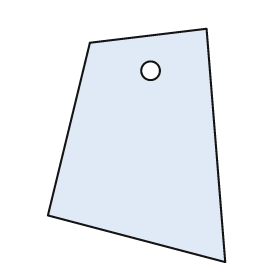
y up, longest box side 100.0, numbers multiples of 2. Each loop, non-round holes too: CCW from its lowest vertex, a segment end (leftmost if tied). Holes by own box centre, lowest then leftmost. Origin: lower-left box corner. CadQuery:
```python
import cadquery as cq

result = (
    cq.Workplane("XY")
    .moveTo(76.0, 0.0)
    .lineTo(68.0, 100.0)
    .lineTo(18.0, 94.0)
    .lineTo(0.0, 20.0)
    .close()
    .moveTo(44.0, 82.0)
    .circle(4.0)
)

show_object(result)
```